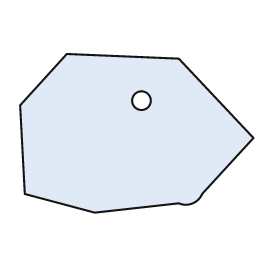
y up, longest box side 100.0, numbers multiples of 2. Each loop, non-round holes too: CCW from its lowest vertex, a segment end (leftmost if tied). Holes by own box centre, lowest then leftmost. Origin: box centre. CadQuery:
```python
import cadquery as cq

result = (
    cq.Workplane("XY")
    .moveTo(-18.0, -34.0)
    .lineTo(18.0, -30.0)
    .threePointArc((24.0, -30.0), (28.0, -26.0))
    .lineTo(50.0, -2.0)
    .lineTo(18.0, 32.0)
    .lineTo(-30.0, 34.0)
    .lineTo(-50.0, 12.0)
    .lineTo(-48.0, -26.0)
    .close()
    .moveTo(2.0, 14.0)
    .circle(4.0)
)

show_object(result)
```